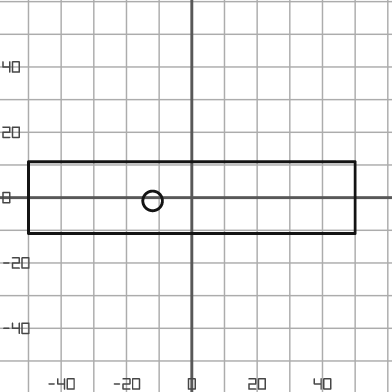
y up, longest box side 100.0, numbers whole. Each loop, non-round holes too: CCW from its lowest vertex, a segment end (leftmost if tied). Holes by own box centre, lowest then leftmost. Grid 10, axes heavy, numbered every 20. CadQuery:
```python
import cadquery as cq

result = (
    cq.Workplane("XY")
    .moveTo(-50.0, -11.0)
    .lineTo(50.0, -11.0)
    .lineTo(50.0, 11.0)
    .lineTo(-50.0, 11.0)
    .close()
    .moveTo(-12.0, -1.0)
    .circle(3.0)
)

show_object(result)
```